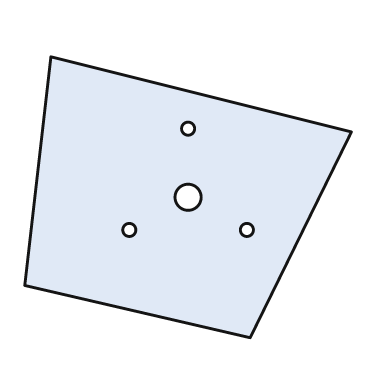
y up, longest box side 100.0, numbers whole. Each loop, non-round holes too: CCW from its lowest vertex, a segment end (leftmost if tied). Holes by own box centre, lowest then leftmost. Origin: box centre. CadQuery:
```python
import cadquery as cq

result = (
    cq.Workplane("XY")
    .moveTo(19.0, -43.0)
    .lineTo(50.0, 20.0)
    .lineTo(-42.0, 43.0)
    .lineTo(-50.0, -27.0)
    .close()
    .moveTo(-18.0, -10.0)
    .circle(2.0)
    .moveTo(18.0, -10.0)
    .circle(2.0)
    .moveTo(0.0, 0.0)
    .circle(4.0)
    .moveTo(0.0, 21.0)
    .circle(2.0)
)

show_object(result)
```